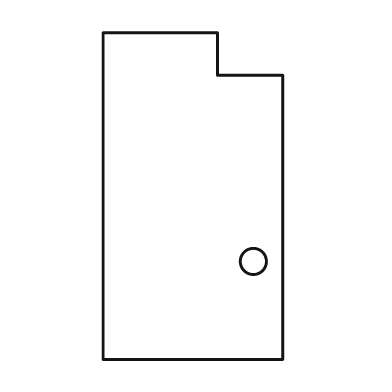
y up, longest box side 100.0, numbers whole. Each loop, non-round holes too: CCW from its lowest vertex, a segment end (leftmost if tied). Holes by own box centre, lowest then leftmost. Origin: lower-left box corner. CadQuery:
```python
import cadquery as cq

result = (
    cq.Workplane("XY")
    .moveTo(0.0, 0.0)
    .lineTo(55.0, 0.0)
    .lineTo(55.0, 87.0)
    .lineTo(35.0, 87.0)
    .lineTo(35.0, 100.0)
    .lineTo(0.0, 100.0)
    .close()
    .moveTo(46.0, 30.0)
    .circle(4.0)
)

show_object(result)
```